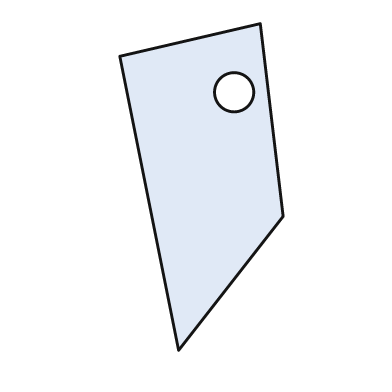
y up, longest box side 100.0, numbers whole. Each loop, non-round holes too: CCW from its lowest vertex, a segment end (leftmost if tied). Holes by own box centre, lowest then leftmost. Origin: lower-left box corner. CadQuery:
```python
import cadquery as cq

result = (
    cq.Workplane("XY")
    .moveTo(18.0, 0.0)
    .lineTo(50.0, 41.0)
    .lineTo(43.0, 100.0)
    .lineTo(0.0, 90.0)
    .close()
    .moveTo(35.0, 79.0)
    .circle(6.0)
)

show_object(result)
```